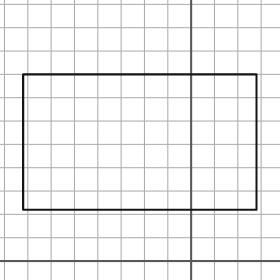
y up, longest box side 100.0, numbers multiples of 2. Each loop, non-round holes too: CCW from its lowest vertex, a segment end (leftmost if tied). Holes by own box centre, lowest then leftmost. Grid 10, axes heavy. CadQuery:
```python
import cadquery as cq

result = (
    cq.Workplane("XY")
    .moveTo(-72.0, 22.0)
    .lineTo(28.0, 22.0)
    .lineTo(28.0, 80.0)
    .lineTo(-72.0, 80.0)
    .close()
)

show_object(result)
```